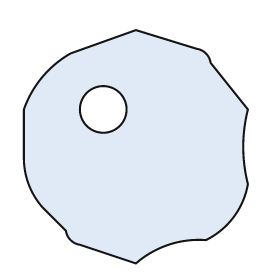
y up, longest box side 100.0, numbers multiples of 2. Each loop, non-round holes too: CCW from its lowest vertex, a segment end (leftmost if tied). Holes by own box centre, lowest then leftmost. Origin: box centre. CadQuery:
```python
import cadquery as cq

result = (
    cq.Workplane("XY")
    .moveTo(0.0, -50.0)
    .threePointArc((14.0, -42.0), (30.0, -40.0))
    .threePointArc((42.0, -30.0), (48.0, -16.0))
    .threePointArc((46.0, 0.0), (48.0, 16.0))
    .lineTo(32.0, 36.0)
    .threePointArc((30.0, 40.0), (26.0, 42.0))
    .lineTo(0.0, 50.0)
    .lineTo(-28.0, 40.0)
    .threePointArc((-40.0, 30.0), (-48.0, 16.0))
    .lineTo(-48.0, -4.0)
    .threePointArc((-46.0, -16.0), (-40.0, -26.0))
    .lineTo(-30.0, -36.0)
    .threePointArc((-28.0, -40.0), (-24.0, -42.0))
    .close()
    .moveTo(-14.0, 16.0)
    .circle(10.0)
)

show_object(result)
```